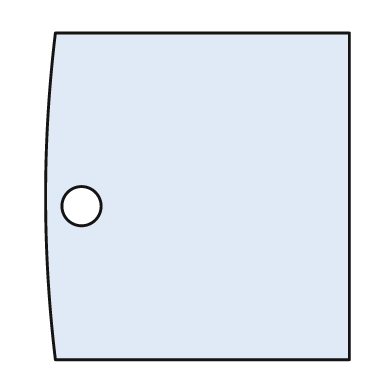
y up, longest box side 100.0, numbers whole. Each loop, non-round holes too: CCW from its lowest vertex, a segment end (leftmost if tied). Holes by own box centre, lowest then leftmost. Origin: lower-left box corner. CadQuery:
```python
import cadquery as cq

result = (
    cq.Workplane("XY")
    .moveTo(3.0, 0.0)
    .lineTo(93.0, 0.0)
    .lineTo(93.0, 100.0)
    .lineTo(3.0, 100.0)
    .threePointArc((0.0, 50.0), (3.0, 0.0))
    .close()
    .moveTo(11.0, 47.0)
    .circle(6.0)
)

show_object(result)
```